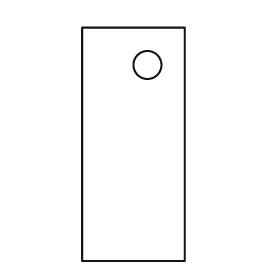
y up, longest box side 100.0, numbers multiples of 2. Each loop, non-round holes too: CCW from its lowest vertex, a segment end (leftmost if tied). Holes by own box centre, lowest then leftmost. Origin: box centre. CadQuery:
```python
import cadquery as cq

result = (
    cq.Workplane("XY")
    .moveTo(-22.0, -50.0)
    .lineTo(22.0, -50.0)
    .lineTo(22.0, 50.0)
    .lineTo(-22.0, 50.0)
    .close()
    .moveTo(6.0, 34.0)
    .circle(6.0)
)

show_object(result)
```